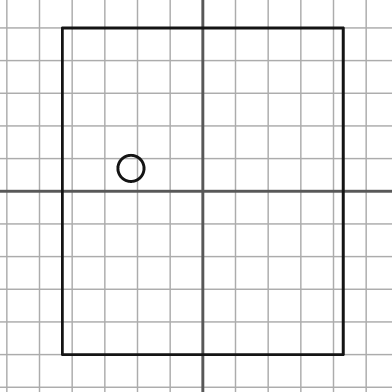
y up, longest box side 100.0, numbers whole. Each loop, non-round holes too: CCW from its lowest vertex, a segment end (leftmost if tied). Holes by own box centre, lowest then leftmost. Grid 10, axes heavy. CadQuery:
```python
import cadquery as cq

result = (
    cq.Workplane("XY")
    .moveTo(-43.0, -50.0)
    .lineTo(43.0, -50.0)
    .lineTo(43.0, 50.0)
    .lineTo(-43.0, 50.0)
    .close()
    .moveTo(-22.0, 7.0)
    .circle(4.0)
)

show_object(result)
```